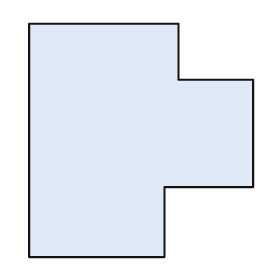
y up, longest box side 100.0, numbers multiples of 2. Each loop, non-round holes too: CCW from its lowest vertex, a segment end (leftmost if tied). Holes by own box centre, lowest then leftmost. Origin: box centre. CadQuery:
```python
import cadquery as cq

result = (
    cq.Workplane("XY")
    .moveTo(-48.0, -50.0)
    .lineTo(10.0, -50.0)
    .lineTo(10.0, -20.0)
    .lineTo(48.0, -20.0)
    .lineTo(48.0, 26.0)
    .lineTo(16.0, 26.0)
    .lineTo(16.0, 50.0)
    .lineTo(-48.0, 50.0)
    .close()
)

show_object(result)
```